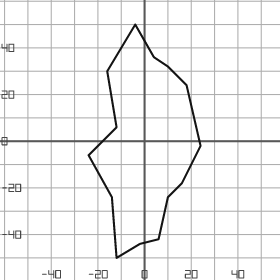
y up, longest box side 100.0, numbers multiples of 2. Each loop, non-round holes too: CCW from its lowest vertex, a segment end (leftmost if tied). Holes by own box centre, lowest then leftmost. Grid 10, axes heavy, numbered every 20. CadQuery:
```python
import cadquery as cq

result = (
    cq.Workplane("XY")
    .moveTo(-12.0, -50.0)
    .lineTo(-2.0, -44.0)
    .lineTo(6.0, -42.0)
    .lineTo(10.0, -24.0)
    .lineTo(16.0, -18.0)
    .lineTo(24.0, -2.0)
    .lineTo(18.0, 24.0)
    .lineTo(10.0, 32.0)
    .lineTo(4.0, 36.0)
    .lineTo(-4.0, 50.0)
    .lineTo(-16.0, 30.0)
    .lineTo(-12.0, 6.0)
    .lineTo(-24.0, -6.0)
    .lineTo(-14.0, -24.0)
    .close()
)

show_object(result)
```